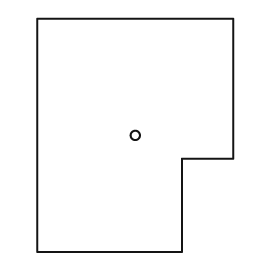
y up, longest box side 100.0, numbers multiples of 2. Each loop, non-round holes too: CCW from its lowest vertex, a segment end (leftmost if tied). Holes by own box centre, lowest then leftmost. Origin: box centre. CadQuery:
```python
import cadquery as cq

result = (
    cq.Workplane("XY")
    .moveTo(-42.0, -50.0)
    .lineTo(20.0, -50.0)
    .lineTo(20.0, -10.0)
    .lineTo(42.0, -10.0)
    .lineTo(42.0, 50.0)
    .lineTo(-42.0, 50.0)
    .close()
    .moveTo(0.0, 0.0)
    .circle(2.0)
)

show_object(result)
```